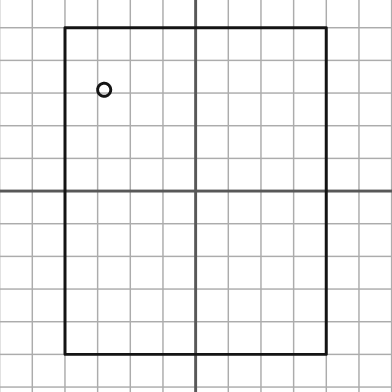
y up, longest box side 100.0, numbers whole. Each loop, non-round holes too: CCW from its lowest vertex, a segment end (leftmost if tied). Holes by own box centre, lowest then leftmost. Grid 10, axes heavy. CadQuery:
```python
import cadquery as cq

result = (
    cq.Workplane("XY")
    .moveTo(-40.0, -50.0)
    .lineTo(40.0, -50.0)
    .lineTo(40.0, 50.0)
    .lineTo(-40.0, 50.0)
    .close()
    .moveTo(-28.0, 31.0)
    .circle(2.0)
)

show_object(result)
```